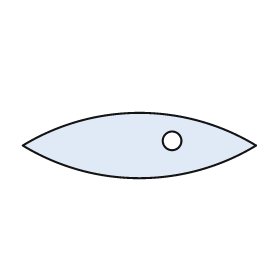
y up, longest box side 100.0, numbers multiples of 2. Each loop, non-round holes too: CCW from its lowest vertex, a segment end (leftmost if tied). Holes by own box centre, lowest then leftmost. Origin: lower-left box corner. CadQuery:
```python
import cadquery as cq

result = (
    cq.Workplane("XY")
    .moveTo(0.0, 14.0)
    .threePointArc((50.0, 0.0), (100.0, 14.0))
    .threePointArc((50.0, 28.0), (0.0, 14.0))
    .close()
    .moveTo(64.0, 16.0)
    .circle(4.0)
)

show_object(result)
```